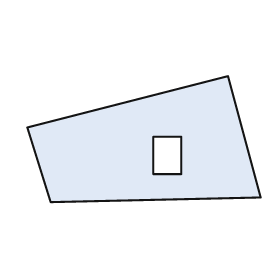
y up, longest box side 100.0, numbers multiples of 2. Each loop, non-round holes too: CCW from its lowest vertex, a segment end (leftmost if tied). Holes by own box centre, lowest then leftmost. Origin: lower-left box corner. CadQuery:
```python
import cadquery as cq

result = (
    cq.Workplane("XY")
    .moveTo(10.0, 0.0)
    .lineTo(100.0, 2.0)
    .lineTo(86.0, 54.0)
    .lineTo(0.0, 32.0)
    .close()
    .moveTo(54.0, 12.0)
    .lineTo(66.0, 12.0)
    .lineTo(66.0, 28.0)
    .lineTo(54.0, 28.0)
    .close()
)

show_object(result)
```